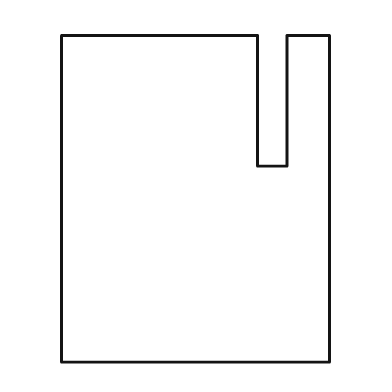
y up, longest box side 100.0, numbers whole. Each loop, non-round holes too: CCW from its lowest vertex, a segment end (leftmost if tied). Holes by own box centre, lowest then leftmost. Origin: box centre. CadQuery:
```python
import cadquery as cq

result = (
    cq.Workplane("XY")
    .moveTo(-41.0, -50.0)
    .lineTo(41.0, -50.0)
    .lineTo(41.0, 50.0)
    .lineTo(28.0, 50.0)
    .lineTo(28.0, 10.0)
    .lineTo(19.0, 10.0)
    .lineTo(19.0, 50.0)
    .lineTo(-41.0, 50.0)
    .close()
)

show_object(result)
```